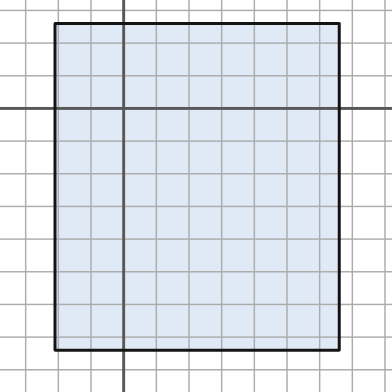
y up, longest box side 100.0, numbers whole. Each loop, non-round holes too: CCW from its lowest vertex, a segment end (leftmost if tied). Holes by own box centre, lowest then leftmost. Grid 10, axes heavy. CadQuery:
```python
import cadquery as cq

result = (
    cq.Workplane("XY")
    .moveTo(-21.0, -74.0)
    .lineTo(66.0, -74.0)
    .lineTo(66.0, 26.0)
    .lineTo(-21.0, 26.0)
    .close()
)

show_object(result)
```